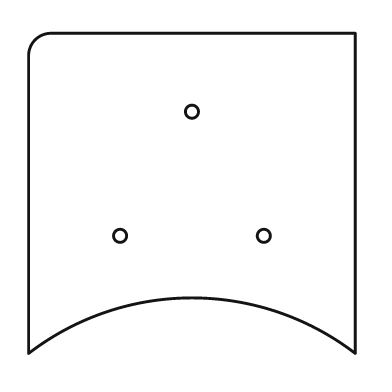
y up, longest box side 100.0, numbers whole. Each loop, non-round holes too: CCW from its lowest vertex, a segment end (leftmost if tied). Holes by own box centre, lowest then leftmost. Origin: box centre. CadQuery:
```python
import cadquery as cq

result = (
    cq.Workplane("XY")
    .moveTo(-50.0, -49.0)
    .threePointArc((0.0, -32.0), (50.0, -49.0))
    .lineTo(50.0, 49.0)
    .lineTo(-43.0, 49.0)
    .threePointArc((-48.0, 47.0), (-50.0, 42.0))
    .close()
    .moveTo(-22.0, -13.0)
    .circle(2.0)
    .moveTo(22.0, -13.0)
    .circle(2.0)
    .moveTo(0.0, 25.0)
    .circle(2.0)
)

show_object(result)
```